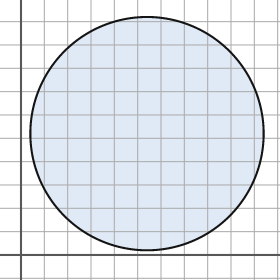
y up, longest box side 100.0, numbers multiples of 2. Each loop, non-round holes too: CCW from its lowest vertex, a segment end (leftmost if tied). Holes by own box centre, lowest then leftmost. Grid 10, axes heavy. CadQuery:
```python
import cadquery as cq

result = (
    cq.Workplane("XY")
    .moveTo(54.0, 52.0)
    .circle(50.0)
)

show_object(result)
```